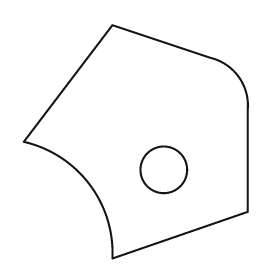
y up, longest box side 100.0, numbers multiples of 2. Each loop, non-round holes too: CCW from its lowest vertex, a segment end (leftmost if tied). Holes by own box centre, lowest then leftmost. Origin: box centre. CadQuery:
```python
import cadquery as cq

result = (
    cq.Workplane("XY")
    .moveTo(-10.0, -50.0)
    .lineTo(48.0, -30.0)
    .lineTo(48.0, 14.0)
    .threePointArc((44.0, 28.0), (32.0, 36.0))
    .lineTo(-10.0, 50.0)
    .lineTo(-48.0, 0.0)
    .threePointArc((-20.0, -18.0), (-10.0, -50.0))
    .close()
    .moveTo(12.0, -12.0)
    .circle(10.0)
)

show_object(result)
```